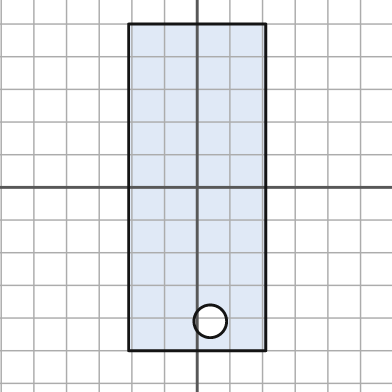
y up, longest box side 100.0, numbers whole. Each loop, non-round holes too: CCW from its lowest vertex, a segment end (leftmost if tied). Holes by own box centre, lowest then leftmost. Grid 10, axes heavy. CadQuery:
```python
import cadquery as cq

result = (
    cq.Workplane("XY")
    .moveTo(-21.0, -50.0)
    .lineTo(21.0, -50.0)
    .lineTo(21.0, 50.0)
    .lineTo(-21.0, 50.0)
    .close()
    .moveTo(4.0, -41.0)
    .circle(5.0)
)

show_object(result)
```